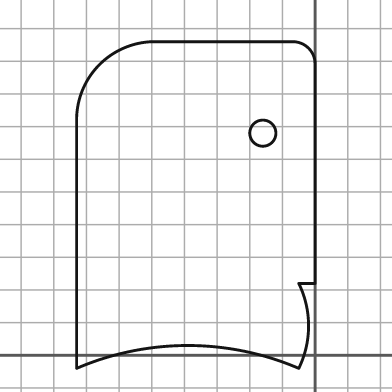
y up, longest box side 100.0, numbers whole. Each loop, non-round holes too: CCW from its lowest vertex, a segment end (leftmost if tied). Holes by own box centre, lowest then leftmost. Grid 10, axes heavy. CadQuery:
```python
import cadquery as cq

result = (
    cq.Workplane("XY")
    .moveTo(-73.0, -4.0)
    .threePointArc((-39.0, 3.0), (-5.0, -4.0))
    .threePointArc((-2.0, 9.0), (-5.0, 22.0))
    .lineTo(0.0, 22.0)
    .lineTo(0.0, 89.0)
    .threePointArc((-2.0, 94.0), (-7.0, 96.0))
    .lineTo(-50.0, 96.0)
    .threePointArc((-66.0, 89.0), (-73.0, 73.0))
    .close()
    .moveTo(-16.0, 68.0)
    .circle(4.0)
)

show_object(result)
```